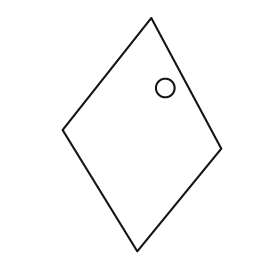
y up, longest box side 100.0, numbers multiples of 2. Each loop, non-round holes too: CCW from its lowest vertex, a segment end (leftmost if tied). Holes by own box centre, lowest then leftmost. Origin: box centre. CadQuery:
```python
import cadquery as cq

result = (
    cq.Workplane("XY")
    .moveTo(-2.0, -50.0)
    .lineTo(34.0, -6.0)
    .lineTo(4.0, 50.0)
    .lineTo(-34.0, 2.0)
    .close()
    .moveTo(10.0, 20.0)
    .circle(4.0)
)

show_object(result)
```